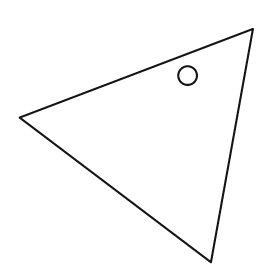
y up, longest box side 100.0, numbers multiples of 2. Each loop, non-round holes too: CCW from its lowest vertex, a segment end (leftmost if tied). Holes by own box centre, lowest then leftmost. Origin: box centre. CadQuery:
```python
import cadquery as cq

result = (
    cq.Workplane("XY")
    .moveTo(32.0, -50.0)
    .lineTo(50.0, 50.0)
    .lineTo(-50.0, 12.0)
    .close()
    .moveTo(22.0, 30.0)
    .circle(4.0)
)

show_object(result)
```